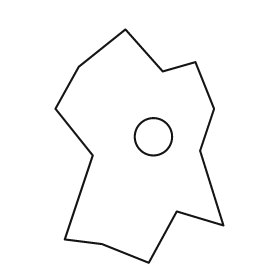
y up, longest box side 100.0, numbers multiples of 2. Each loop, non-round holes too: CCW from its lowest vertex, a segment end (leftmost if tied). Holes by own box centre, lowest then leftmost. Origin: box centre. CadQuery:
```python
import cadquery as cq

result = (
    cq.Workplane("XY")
    .moveTo(4.0, -50.0)
    .lineTo(16.0, -28.0)
    .lineTo(36.0, -34.0)
    .lineTo(26.0, -2.0)
    .lineTo(32.0, 16.0)
    .lineTo(24.0, 36.0)
    .lineTo(10.0, 32.0)
    .lineTo(-6.0, 50.0)
    .lineTo(-26.0, 34.0)
    .lineTo(-36.0, 16.0)
    .lineTo(-20.0, -4.0)
    .lineTo(-32.0, -40.0)
    .lineTo(-16.0, -42.0)
    .close()
    .moveTo(6.0, 4.0)
    .circle(8.0)
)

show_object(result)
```